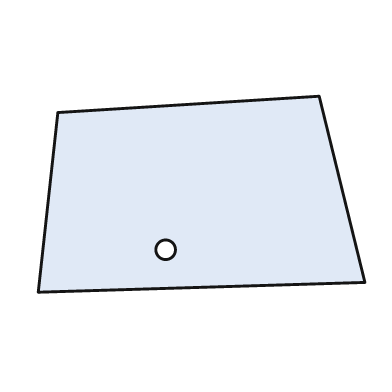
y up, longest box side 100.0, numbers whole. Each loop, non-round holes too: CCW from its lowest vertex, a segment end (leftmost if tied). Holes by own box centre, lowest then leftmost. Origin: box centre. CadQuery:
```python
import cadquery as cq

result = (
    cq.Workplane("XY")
    .moveTo(-50.0, -30.0)
    .lineTo(50.0, -27.0)
    .lineTo(36.0, 30.0)
    .lineTo(-44.0, 25.0)
    .close()
    .moveTo(-11.0, -17.0)
    .circle(3.0)
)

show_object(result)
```